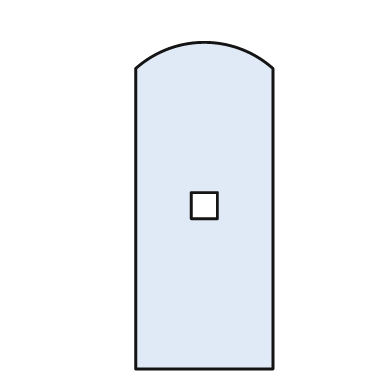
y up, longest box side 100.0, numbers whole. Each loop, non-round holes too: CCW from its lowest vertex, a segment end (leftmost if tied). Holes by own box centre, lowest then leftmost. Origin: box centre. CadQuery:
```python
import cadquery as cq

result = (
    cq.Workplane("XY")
    .moveTo(-21.0, -50.0)
    .lineTo(21.0, -50.0)
    .lineTo(21.0, 42.0)
    .threePointArc((0.0, 50.0), (-21.0, 42.0))
    .close()
    .moveTo(-4.0, -4.0)
    .lineTo(4.0, -4.0)
    .lineTo(4.0, 4.0)
    .lineTo(-4.0, 4.0)
    .close()
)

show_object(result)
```